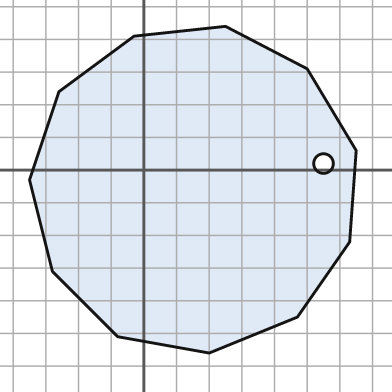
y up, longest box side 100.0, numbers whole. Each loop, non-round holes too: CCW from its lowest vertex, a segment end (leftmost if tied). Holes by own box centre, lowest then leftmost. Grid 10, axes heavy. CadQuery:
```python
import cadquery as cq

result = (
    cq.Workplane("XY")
    .moveTo(20.0, -56.0)
    .lineTo(47.0, -45.0)
    .lineTo(63.0, -22.0)
    .lineTo(65.0, 6.0)
    .lineTo(50.0, 31.0)
    .lineTo(25.0, 44.0)
    .lineTo(-3.0, 41.0)
    .lineTo(-26.0, 24.0)
    .lineTo(-35.0, -3.0)
    .lineTo(-28.0, -31.0)
    .lineTo(-8.0, -51.0)
    .close()
    .moveTo(55.0, 2.0)
    .circle(3.0)
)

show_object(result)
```